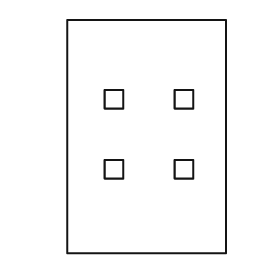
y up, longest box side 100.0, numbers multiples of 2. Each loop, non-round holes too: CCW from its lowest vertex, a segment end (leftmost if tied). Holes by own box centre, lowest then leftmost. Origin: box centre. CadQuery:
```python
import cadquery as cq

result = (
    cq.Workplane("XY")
    .moveTo(-34.0, -50.0)
    .lineTo(34.0, -50.0)
    .lineTo(34.0, 50.0)
    .lineTo(-34.0, 50.0)
    .close()
    .moveTo(-18.0, -18.0)
    .lineTo(-10.0, -18.0)
    .lineTo(-10.0, -10.0)
    .lineTo(-18.0, -10.0)
    .close()
    .moveTo(12.0, -18.0)
    .lineTo(20.0, -18.0)
    .lineTo(20.0, -10.0)
    .lineTo(12.0, -10.0)
    .close()
    .moveTo(-18.0, 12.0)
    .lineTo(-10.0, 12.0)
    .lineTo(-10.0, 20.0)
    .lineTo(-18.0, 20.0)
    .close()
    .moveTo(12.0, 12.0)
    .lineTo(20.0, 12.0)
    .lineTo(20.0, 20.0)
    .lineTo(12.0, 20.0)
    .close()
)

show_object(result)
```